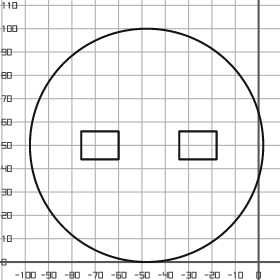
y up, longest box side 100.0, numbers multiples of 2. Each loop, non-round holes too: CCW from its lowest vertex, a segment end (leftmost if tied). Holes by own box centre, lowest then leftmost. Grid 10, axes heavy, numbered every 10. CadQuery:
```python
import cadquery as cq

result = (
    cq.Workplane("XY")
    .moveTo(-48.0, 50.0)
    .circle(50.0)
    .moveTo(-76.0, 44.0)
    .lineTo(-60.0, 44.0)
    .lineTo(-60.0, 56.0)
    .lineTo(-76.0, 56.0)
    .close()
    .moveTo(-34.0, 44.0)
    .lineTo(-18.0, 44.0)
    .lineTo(-18.0, 56.0)
    .lineTo(-34.0, 56.0)
    .close()
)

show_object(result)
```